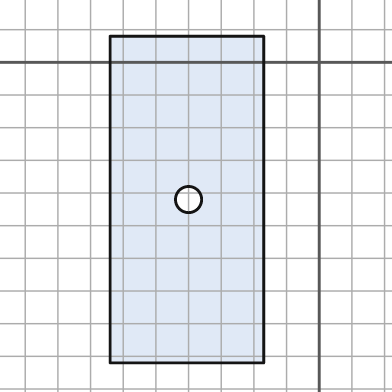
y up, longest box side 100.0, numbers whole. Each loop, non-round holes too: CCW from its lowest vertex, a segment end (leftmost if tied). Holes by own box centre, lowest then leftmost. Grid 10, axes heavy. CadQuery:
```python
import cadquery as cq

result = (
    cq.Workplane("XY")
    .moveTo(-64.0, -92.0)
    .lineTo(-17.0, -92.0)
    .lineTo(-17.0, 8.0)
    .lineTo(-64.0, 8.0)
    .close()
    .moveTo(-40.0, -42.0)
    .circle(4.0)
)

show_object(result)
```